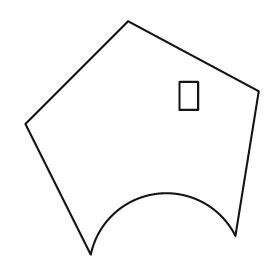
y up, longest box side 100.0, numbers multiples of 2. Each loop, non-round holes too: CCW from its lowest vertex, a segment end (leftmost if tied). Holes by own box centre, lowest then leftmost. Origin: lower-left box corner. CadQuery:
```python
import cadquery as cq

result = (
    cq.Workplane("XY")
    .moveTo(28.0, 0.0)
    .threePointArc((56.0, 26.0), (90.0, 8.0))
    .lineTo(100.0, 70.0)
    .lineTo(44.0, 100.0)
    .lineTo(0.0, 56.0)
    .close()
    .moveTo(66.0, 62.0)
    .lineTo(74.0, 62.0)
    .lineTo(74.0, 74.0)
    .lineTo(66.0, 74.0)
    .close()
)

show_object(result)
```